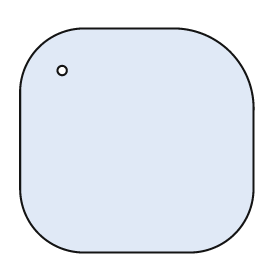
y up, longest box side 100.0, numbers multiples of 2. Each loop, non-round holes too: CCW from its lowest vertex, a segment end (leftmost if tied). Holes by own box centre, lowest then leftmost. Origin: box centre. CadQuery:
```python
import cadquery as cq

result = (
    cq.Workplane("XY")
    .moveTo(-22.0, -48.0)
    .lineTo(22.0, -48.0)
    .threePointArc((42.0, -40.0), (50.0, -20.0))
    .lineTo(50.0, 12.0)
    .threePointArc((40.0, 38.0), (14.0, 48.0))
    .lineTo(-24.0, 48.0)
    .threePointArc((-42.0, 40.0), (-50.0, 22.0))
    .lineTo(-50.0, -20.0)
    .threePointArc((-42.0, -40.0), (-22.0, -48.0))
    .close()
    .moveTo(-32.0, 30.0)
    .circle(2.0)
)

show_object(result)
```